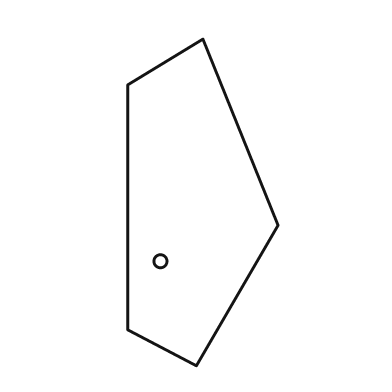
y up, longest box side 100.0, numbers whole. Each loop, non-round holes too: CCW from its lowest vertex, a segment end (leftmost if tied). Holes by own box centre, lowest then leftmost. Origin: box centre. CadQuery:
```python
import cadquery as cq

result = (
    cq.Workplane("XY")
    .moveTo(-2.0, -50.0)
    .lineTo(23.0, -7.0)
    .lineTo(0.0, 50.0)
    .lineTo(-23.0, 36.0)
    .lineTo(-23.0, -39.0)
    .close()
    .moveTo(-13.0, -18.0)
    .circle(2.0)
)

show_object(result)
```